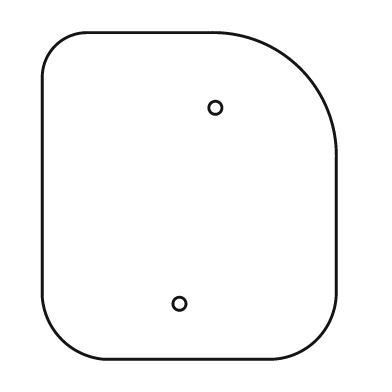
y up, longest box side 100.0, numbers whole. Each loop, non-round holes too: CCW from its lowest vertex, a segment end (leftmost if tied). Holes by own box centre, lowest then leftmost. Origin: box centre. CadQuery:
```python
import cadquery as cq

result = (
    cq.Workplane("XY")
    .moveTo(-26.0, -50.0)
    .lineTo(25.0, -50.0)
    .threePointArc((39.0, -44.0), (45.0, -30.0))
    .lineTo(45.0, 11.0)
    .threePointArc((34.0, 39.0), (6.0, 50.0))
    .lineTo(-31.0, 50.0)
    .threePointArc((-41.0, 46.0), (-45.0, 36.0))
    .lineTo(-45.0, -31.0)
    .threePointArc((-39.0, -44.0), (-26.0, -50.0))
    .close()
    .moveTo(-3.0, -33.0)
    .circle(2.0)
    .moveTo(8.0, 27.0)
    .circle(2.0)
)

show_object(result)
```